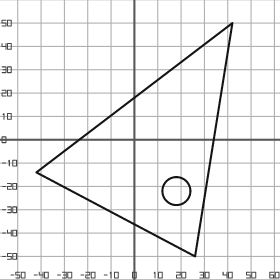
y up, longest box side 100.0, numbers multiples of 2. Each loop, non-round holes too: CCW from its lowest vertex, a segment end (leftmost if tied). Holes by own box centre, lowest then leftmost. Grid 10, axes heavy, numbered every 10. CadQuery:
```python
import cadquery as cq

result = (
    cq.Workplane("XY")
    .moveTo(26.0, -50.0)
    .lineTo(42.0, 50.0)
    .lineTo(-42.0, -14.0)
    .close()
    .moveTo(18.0, -22.0)
    .circle(6.0)
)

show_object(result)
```